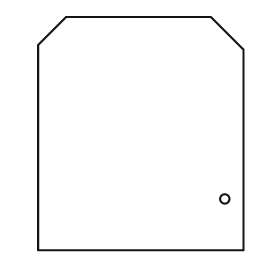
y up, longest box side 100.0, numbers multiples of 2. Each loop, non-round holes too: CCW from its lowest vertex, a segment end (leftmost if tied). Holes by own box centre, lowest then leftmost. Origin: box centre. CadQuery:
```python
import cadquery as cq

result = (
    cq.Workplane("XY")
    .moveTo(-44.0, -50.0)
    .lineTo(44.0, -50.0)
    .lineTo(44.0, 36.0)
    .lineTo(30.0, 50.0)
    .lineTo(-32.0, 50.0)
    .lineTo(-44.0, 38.0)
    .close()
    .moveTo(36.0, -28.0)
    .circle(2.0)
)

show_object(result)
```